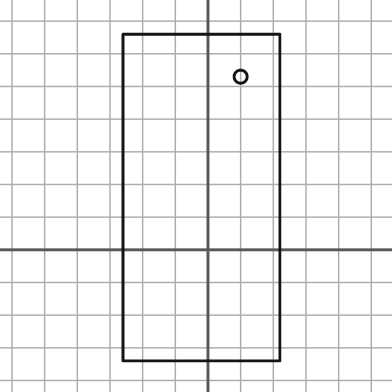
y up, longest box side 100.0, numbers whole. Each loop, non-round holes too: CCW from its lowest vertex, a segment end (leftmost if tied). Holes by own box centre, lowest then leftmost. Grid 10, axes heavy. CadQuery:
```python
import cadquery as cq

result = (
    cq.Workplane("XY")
    .moveTo(-26.0, -34.0)
    .lineTo(22.0, -34.0)
    .lineTo(22.0, 66.0)
    .lineTo(-26.0, 66.0)
    .close()
    .moveTo(10.0, 53.0)
    .circle(2.0)
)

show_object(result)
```